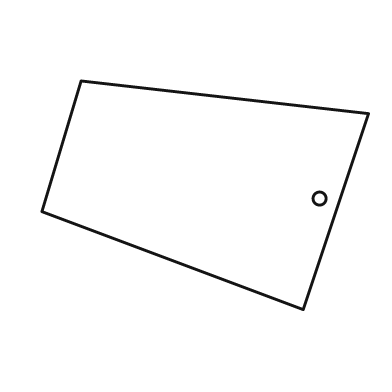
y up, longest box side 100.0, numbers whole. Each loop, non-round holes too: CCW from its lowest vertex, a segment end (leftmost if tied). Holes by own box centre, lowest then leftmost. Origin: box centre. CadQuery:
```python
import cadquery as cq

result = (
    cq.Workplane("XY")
    .moveTo(30.0, -35.0)
    .lineTo(50.0, 25.0)
    .lineTo(-38.0, 35.0)
    .lineTo(-50.0, -5.0)
    .close()
    .moveTo(35.0, -1.0)
    .circle(2.0)
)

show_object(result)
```